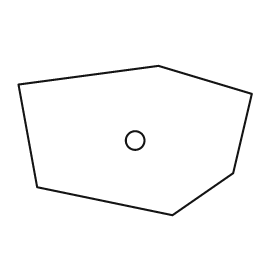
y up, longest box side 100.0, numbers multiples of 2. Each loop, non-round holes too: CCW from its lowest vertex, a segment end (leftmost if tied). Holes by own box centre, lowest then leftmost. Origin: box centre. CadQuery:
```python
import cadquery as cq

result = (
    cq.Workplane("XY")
    .moveTo(16.0, -32.0)
    .lineTo(42.0, -14.0)
    .lineTo(50.0, 20.0)
    .lineTo(10.0, 32.0)
    .lineTo(-50.0, 24.0)
    .lineTo(-42.0, -20.0)
    .close()
    .moveTo(0.0, 0.0)
    .circle(4.0)
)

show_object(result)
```